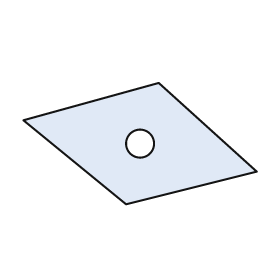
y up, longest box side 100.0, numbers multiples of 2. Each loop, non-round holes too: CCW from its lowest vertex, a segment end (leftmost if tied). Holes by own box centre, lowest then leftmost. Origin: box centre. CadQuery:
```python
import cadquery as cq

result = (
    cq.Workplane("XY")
    .moveTo(-6.0, -26.0)
    .lineTo(50.0, -12.0)
    .lineTo(8.0, 26.0)
    .lineTo(-50.0, 10.0)
    .close()
    .moveTo(0.0, 0.0)
    .circle(6.0)
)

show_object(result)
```